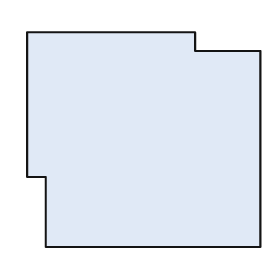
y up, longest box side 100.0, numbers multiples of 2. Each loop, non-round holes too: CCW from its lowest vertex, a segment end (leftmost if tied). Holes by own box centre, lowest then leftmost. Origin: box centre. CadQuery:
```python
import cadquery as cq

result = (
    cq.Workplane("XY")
    .moveTo(-42.0, -46.0)
    .lineTo(50.0, -46.0)
    .lineTo(50.0, 38.0)
    .lineTo(22.0, 38.0)
    .lineTo(22.0, 46.0)
    .lineTo(-50.0, 46.0)
    .lineTo(-50.0, -16.0)
    .lineTo(-42.0, -16.0)
    .close()
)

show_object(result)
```